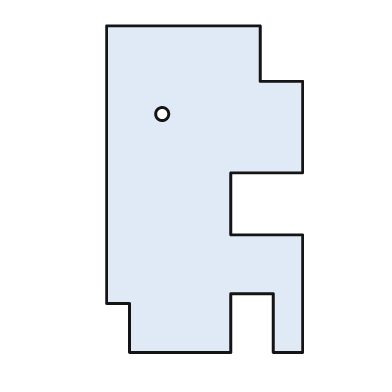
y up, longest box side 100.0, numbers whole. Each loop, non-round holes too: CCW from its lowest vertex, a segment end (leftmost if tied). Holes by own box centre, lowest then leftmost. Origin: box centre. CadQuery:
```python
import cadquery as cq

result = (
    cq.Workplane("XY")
    .moveTo(-23.0, -50.0)
    .lineTo(8.0, -50.0)
    .lineTo(8.0, -32.0)
    .lineTo(21.0, -32.0)
    .lineTo(21.0, -50.0)
    .lineTo(30.0, -50.0)
    .lineTo(30.0, -14.0)
    .lineTo(8.0, -14.0)
    .lineTo(8.0, 5.0)
    .lineTo(30.0, 5.0)
    .lineTo(30.0, 33.0)
    .lineTo(17.0, 33.0)
    .lineTo(17.0, 50.0)
    .lineTo(-30.0, 50.0)
    .lineTo(-30.0, -35.0)
    .lineTo(-23.0, -35.0)
    .close()
    .moveTo(-13.0, 23.0)
    .circle(2.0)
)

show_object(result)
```